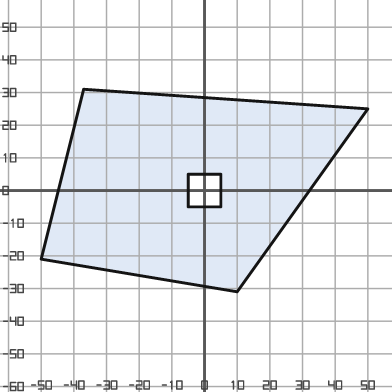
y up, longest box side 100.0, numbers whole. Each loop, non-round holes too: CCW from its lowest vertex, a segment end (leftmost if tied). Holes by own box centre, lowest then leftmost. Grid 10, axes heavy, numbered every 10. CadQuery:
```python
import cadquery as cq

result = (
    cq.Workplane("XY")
    .moveTo(10.0, -31.0)
    .lineTo(50.0, 25.0)
    .lineTo(-37.0, 31.0)
    .lineTo(-50.0, -21.0)
    .close()
    .moveTo(-5.0, -5.0)
    .lineTo(5.0, -5.0)
    .lineTo(5.0, 5.0)
    .lineTo(-5.0, 5.0)
    .close()
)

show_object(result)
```